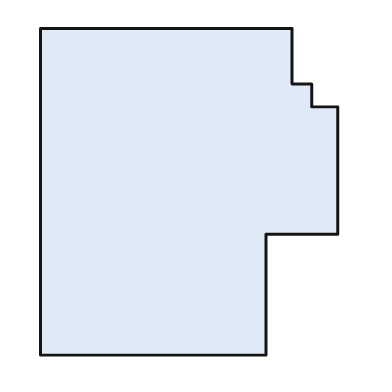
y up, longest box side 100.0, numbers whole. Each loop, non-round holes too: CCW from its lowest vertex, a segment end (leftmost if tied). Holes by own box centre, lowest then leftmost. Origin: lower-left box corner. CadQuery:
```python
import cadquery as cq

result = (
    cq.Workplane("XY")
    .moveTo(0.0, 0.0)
    .lineTo(69.0, 0.0)
    .lineTo(69.0, 37.0)
    .lineTo(91.0, 37.0)
    .lineTo(91.0, 76.0)
    .lineTo(83.0, 76.0)
    .lineTo(83.0, 83.0)
    .lineTo(77.0, 83.0)
    .lineTo(77.0, 100.0)
    .lineTo(0.0, 100.0)
    .close()
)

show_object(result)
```